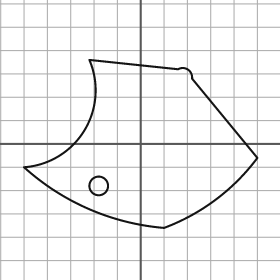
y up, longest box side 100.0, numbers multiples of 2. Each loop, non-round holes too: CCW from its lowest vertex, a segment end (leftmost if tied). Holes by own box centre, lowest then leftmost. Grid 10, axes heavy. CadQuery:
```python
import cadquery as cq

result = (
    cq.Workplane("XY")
    .moveTo(10.0, -36.0)
    .threePointArc((32.0, -24.0), (50.0, -6.0))
    .lineTo(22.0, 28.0)
    .threePointArc((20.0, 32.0), (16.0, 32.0))
    .lineTo(-22.0, 36.0)
    .threePointArc((-24.0, 6.0), (-50.0, -10.0))
    .threePointArc((-22.0, -28.0), (10.0, -36.0))
    .close()
    .moveTo(-18.0, -18.0)
    .circle(4.0)
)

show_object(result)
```